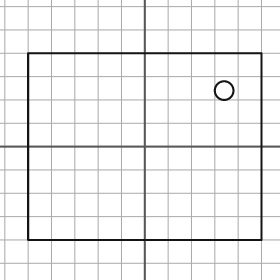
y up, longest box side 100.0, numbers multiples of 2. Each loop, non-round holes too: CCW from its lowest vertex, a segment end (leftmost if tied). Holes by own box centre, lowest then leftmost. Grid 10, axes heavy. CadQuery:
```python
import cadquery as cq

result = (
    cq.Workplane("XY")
    .moveTo(-50.0, -40.0)
    .lineTo(50.0, -40.0)
    .lineTo(50.0, 40.0)
    .lineTo(-50.0, 40.0)
    .close()
    .moveTo(34.0, 24.0)
    .circle(4.0)
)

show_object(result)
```